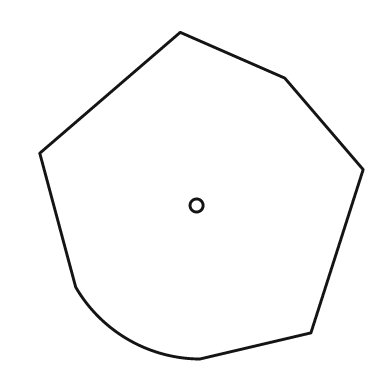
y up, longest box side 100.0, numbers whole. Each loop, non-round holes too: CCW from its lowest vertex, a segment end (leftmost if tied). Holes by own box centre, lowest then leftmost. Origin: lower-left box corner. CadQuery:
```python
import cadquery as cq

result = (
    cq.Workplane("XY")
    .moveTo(49.0, 0.0)
    .lineTo(83.0, 8.0)
    .lineTo(99.0, 58.0)
    .lineTo(75.0, 86.0)
    .lineTo(43.0, 100.0)
    .lineTo(0.0, 63.0)
    .lineTo(11.0, 22.0)
    .threePointArc((27.0, 6.0), (49.0, 0.0))
    .close()
    .moveTo(48.0, 47.0)
    .circle(2.0)
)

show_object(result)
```